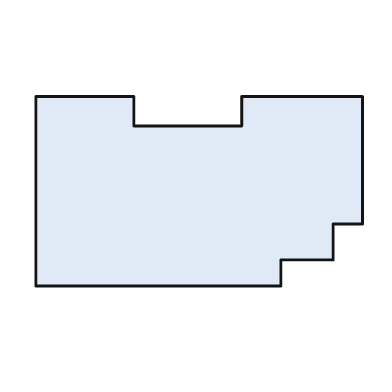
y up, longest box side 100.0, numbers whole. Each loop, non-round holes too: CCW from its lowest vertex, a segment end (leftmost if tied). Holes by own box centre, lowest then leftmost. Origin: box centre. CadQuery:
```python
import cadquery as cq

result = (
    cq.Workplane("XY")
    .moveTo(-50.0, -29.0)
    .lineTo(25.0, -29.0)
    .lineTo(25.0, -21.0)
    .lineTo(41.0, -21.0)
    .lineTo(41.0, -10.0)
    .lineTo(50.0, -10.0)
    .lineTo(50.0, 29.0)
    .lineTo(13.0, 29.0)
    .lineTo(13.0, 20.0)
    .lineTo(-20.0, 20.0)
    .lineTo(-20.0, 29.0)
    .lineTo(-50.0, 29.0)
    .close()
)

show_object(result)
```